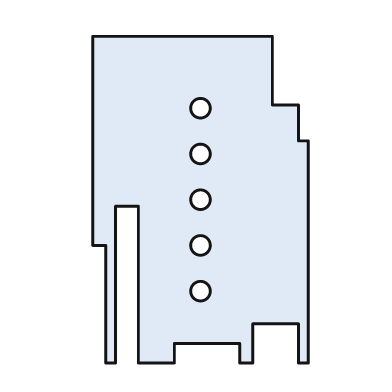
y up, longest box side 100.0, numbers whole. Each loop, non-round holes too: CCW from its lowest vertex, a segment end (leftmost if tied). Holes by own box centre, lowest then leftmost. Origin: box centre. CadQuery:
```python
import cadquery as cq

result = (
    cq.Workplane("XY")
    .moveTo(-29.0, -50.0)
    .lineTo(-26.0, -50.0)
    .lineTo(-26.0, -2.0)
    .lineTo(-19.0, -2.0)
    .lineTo(-19.0, -50.0)
    .lineTo(-8.0, -50.0)
    .lineTo(-8.0, -44.0)
    .lineTo(12.0, -44.0)
    .lineTo(12.0, -50.0)
    .lineTo(16.0, -50.0)
    .lineTo(16.0, -38.0)
    .lineTo(30.0, -38.0)
    .lineTo(30.0, -50.0)
    .lineTo(33.0, -50.0)
    .lineTo(33.0, 18.0)
    .lineTo(30.0, 18.0)
    .lineTo(30.0, 29.0)
    .lineTo(22.0, 29.0)
    .lineTo(22.0, 50.0)
    .lineTo(-33.0, 50.0)
    .lineTo(-33.0, -14.0)
    .lineTo(-29.0, -14.0)
    .close()
    .moveTo(0.0, -28.0)
    .circle(3.0)
    .moveTo(0.0, -14.0)
    .circle(3.0)
    .moveTo(0.0, 0.0)
    .circle(3.0)
    .moveTo(0.0, 14.0)
    .circle(3.0)
    .moveTo(0.0, 28.0)
    .circle(3.0)
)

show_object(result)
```